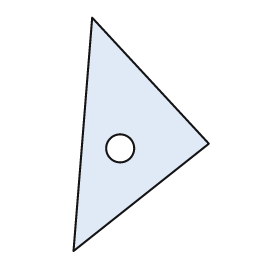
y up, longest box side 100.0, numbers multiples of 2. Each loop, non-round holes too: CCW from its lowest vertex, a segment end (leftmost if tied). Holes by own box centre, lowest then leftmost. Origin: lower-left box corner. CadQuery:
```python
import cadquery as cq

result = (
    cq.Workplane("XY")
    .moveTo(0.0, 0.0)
    .lineTo(58.0, 46.0)
    .lineTo(8.0, 100.0)
    .close()
    .moveTo(20.0, 44.0)
    .circle(6.0)
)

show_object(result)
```